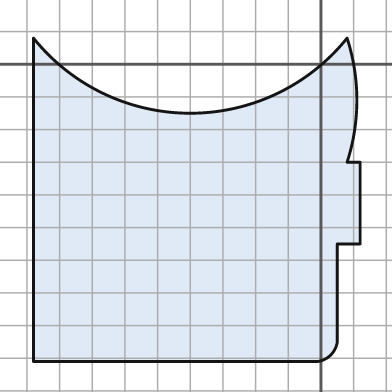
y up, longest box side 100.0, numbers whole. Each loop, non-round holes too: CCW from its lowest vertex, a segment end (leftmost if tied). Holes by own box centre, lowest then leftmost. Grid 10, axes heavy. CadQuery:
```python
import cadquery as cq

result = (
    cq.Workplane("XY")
    .moveTo(-88.0, -91.0)
    .lineTo(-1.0, -91.0)
    .threePointArc((3.0, -89.0), (5.0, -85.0))
    .lineTo(5.0, -55.0)
    .lineTo(12.0, -55.0)
    .lineTo(12.0, -30.0)
    .lineTo(8.0, -30.0)
    .threePointArc((11.0, -11.0), (8.0, 8.0))
    .threePointArc((-40.0, -15.0), (-88.0, 8.0))
    .close()
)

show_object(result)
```